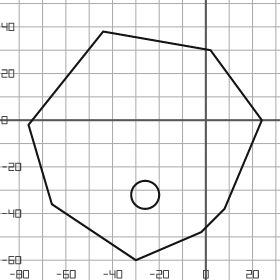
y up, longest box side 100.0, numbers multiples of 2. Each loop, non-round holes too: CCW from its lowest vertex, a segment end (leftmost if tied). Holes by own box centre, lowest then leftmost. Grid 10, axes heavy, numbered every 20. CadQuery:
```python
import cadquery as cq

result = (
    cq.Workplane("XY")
    .moveTo(-30.0, -60.0)
    .lineTo(-2.0, -48.0)
    .lineTo(8.0, -38.0)
    .lineTo(24.0, 0.0)
    .lineTo(2.0, 30.0)
    .lineTo(-44.0, 38.0)
    .lineTo(-76.0, -2.0)
    .lineTo(-66.0, -36.0)
    .close()
    .moveTo(-26.0, -32.0)
    .circle(6.0)
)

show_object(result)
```